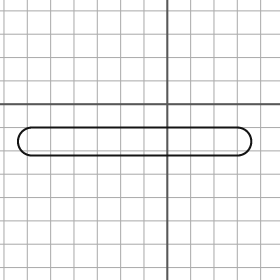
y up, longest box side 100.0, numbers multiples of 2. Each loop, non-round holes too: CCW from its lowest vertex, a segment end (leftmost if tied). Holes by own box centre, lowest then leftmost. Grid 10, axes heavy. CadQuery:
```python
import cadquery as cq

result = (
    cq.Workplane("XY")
    .moveTo(-58.0, -22.0)
    .lineTo(30.0, -22.0)
    .threePointArc((36.0, -16.0), (30.0, -10.0))
    .lineTo(-58.0, -10.0)
    .threePointArc((-64.0, -16.0), (-58.0, -22.0))
    .close()
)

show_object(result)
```